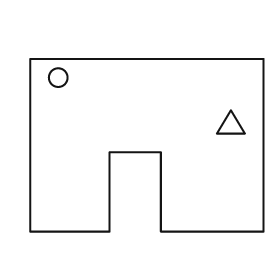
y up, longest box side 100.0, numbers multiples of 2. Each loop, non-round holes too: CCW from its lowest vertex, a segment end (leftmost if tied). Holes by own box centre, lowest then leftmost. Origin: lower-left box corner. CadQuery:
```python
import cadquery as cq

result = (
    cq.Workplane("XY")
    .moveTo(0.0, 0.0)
    .lineTo(34.0, 0.0)
    .lineTo(34.0, 34.0)
    .lineTo(56.0, 34.0)
    .lineTo(56.0, 0.0)
    .lineTo(100.0, 0.0)
    .lineTo(100.0, 74.0)
    .lineTo(0.0, 74.0)
    .close()
    .moveTo(80.0, 42.0)
    .lineTo(92.0, 42.0)
    .lineTo(86.0, 52.0)
    .close()
    .moveTo(12.0, 66.0)
    .circle(4.0)
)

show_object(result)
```